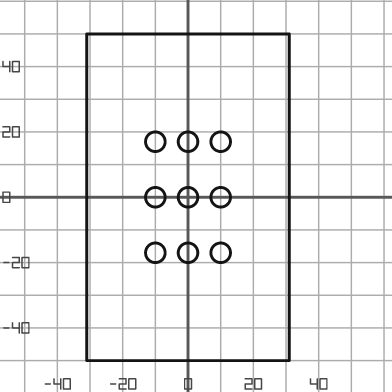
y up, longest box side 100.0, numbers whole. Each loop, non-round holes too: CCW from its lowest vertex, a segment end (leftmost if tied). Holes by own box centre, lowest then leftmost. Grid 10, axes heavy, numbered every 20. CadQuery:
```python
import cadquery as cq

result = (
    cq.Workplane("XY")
    .moveTo(-31.0, -50.0)
    .lineTo(31.0, -50.0)
    .lineTo(31.0, 50.0)
    .lineTo(-31.0, 50.0)
    .close()
    .moveTo(-10.0, -17.0)
    .circle(3.0)
    .moveTo(0.0, -17.0)
    .circle(3.0)
    .moveTo(10.0, -17.0)
    .circle(3.0)
    .moveTo(-10.0, 0.0)
    .circle(3.0)
    .moveTo(0.0, 0.0)
    .circle(3.0)
    .moveTo(10.0, 0.0)
    .circle(3.0)
    .moveTo(-10.0, 17.0)
    .circle(3.0)
    .moveTo(0.0, 17.0)
    .circle(3.0)
    .moveTo(10.0, 17.0)
    .circle(3.0)
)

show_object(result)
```